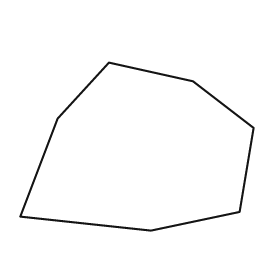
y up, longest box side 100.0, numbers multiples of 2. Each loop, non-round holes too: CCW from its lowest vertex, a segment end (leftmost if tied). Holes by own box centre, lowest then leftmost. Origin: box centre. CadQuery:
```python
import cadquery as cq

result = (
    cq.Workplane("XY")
    .moveTo(6.0, -36.0)
    .lineTo(44.0, -28.0)
    .lineTo(50.0, 8.0)
    .lineTo(24.0, 28.0)
    .lineTo(-12.0, 36.0)
    .lineTo(-34.0, 12.0)
    .lineTo(-50.0, -30.0)
    .close()
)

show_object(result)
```